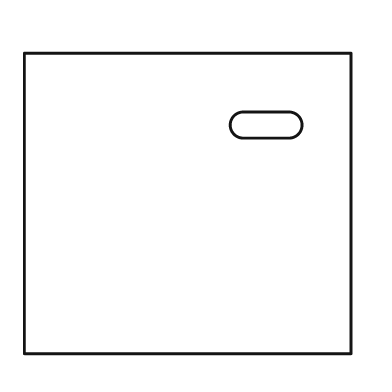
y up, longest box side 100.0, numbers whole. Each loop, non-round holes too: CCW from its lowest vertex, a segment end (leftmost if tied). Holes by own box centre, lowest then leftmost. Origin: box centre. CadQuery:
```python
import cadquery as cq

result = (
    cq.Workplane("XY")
    .moveTo(-50.0, -46.0)
    .lineTo(50.0, -46.0)
    .lineTo(50.0, 46.0)
    .lineTo(-50.0, 46.0)
    .close()
    .moveTo(17.0, 20.0)
    .lineTo(31.0, 20.0)
    .threePointArc((35.0, 24.0), (31.0, 28.0))
    .lineTo(17.0, 28.0)
    .threePointArc((13.0, 24.0), (17.0, 20.0))
    .close()
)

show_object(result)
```